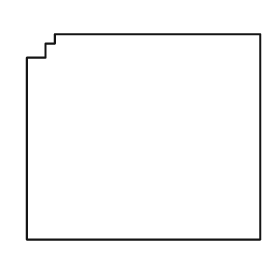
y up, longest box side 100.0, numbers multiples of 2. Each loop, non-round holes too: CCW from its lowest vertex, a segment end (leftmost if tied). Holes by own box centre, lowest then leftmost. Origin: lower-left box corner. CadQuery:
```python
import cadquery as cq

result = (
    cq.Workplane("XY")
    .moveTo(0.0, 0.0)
    .lineTo(100.0, 0.0)
    .lineTo(100.0, 88.0)
    .lineTo(12.0, 88.0)
    .lineTo(12.0, 84.0)
    .lineTo(8.0, 84.0)
    .lineTo(8.0, 78.0)
    .lineTo(0.0, 78.0)
    .close()
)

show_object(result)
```